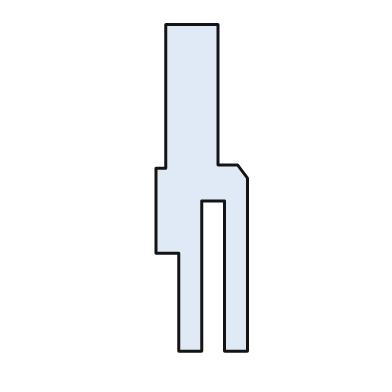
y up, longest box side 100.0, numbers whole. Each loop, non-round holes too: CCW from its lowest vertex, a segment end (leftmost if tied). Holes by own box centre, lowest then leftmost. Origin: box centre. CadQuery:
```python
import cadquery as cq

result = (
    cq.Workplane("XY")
    .moveTo(-7.0, -50.0)
    .lineTo(0.0, -50.0)
    .lineTo(0.0, -4.0)
    .lineTo(7.0, -4.0)
    .lineTo(7.0, -50.0)
    .lineTo(14.0, -50.0)
    .lineTo(14.0, 3.0)
    .lineTo(11.0, 7.0)
    .lineTo(5.0, 7.0)
    .lineTo(5.0, 50.0)
    .lineTo(-11.0, 50.0)
    .lineTo(-11.0, 6.0)
    .lineTo(-14.0, 6.0)
    .lineTo(-14.0, -20.0)
    .lineTo(-7.0, -20.0)
    .close()
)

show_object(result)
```